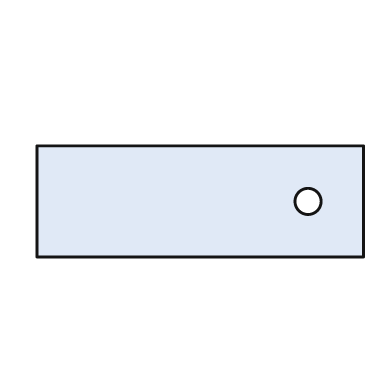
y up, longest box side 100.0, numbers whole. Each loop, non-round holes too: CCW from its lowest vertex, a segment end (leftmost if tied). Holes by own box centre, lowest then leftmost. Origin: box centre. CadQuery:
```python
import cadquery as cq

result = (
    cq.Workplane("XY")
    .moveTo(-50.0, -17.0)
    .lineTo(50.0, -17.0)
    .lineTo(50.0, 17.0)
    .lineTo(-50.0, 17.0)
    .close()
    .moveTo(33.0, 0.0)
    .circle(4.0)
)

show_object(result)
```